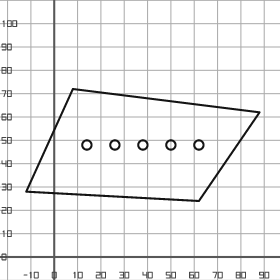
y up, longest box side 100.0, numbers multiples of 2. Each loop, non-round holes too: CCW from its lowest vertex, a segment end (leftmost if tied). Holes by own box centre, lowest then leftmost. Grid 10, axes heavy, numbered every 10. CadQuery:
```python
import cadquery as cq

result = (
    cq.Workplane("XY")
    .moveTo(62.0, 24.0)
    .lineTo(88.0, 62.0)
    .lineTo(8.0, 72.0)
    .lineTo(-12.0, 28.0)
    .close()
    .moveTo(14.0, 48.0)
    .circle(2.0)
    .moveTo(26.0, 48.0)
    .circle(2.0)
    .moveTo(38.0, 48.0)
    .circle(2.0)
    .moveTo(50.0, 48.0)
    .circle(2.0)
    .moveTo(62.0, 48.0)
    .circle(2.0)
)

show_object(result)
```